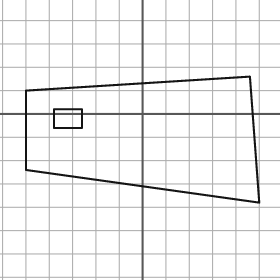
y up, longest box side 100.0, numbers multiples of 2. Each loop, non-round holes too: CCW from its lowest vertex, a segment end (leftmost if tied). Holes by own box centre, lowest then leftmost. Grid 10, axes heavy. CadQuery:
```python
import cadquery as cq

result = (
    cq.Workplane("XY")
    .moveTo(50.0, -38.0)
    .lineTo(46.0, 16.0)
    .lineTo(-50.0, 10.0)
    .lineTo(-50.0, -24.0)
    .close()
    .moveTo(-38.0, -6.0)
    .lineTo(-26.0, -6.0)
    .lineTo(-26.0, 2.0)
    .lineTo(-38.0, 2.0)
    .close()
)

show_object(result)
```